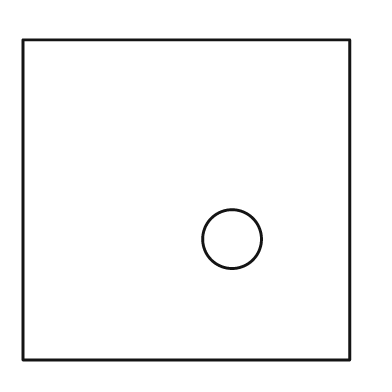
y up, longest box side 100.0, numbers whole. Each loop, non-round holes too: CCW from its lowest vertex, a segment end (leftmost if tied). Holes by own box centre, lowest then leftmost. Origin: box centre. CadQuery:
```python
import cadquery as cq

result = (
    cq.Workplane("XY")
    .moveTo(-50.0, -49.0)
    .lineTo(50.0, -49.0)
    .lineTo(50.0, 49.0)
    .lineTo(-50.0, 49.0)
    .close()
    .moveTo(14.0, -12.0)
    .circle(9.0)
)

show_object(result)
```